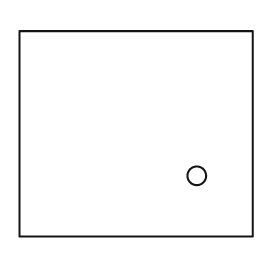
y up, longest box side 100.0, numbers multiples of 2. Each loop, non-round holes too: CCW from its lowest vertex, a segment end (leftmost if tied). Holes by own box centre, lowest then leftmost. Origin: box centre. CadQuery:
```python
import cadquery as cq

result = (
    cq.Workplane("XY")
    .moveTo(-50.0, -44.0)
    .lineTo(50.0, -44.0)
    .lineTo(50.0, 44.0)
    .lineTo(-50.0, 44.0)
    .close()
    .moveTo(26.0, -18.0)
    .circle(4.0)
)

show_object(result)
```